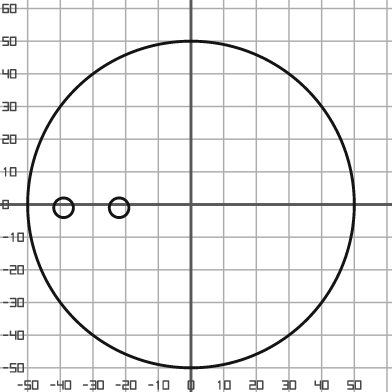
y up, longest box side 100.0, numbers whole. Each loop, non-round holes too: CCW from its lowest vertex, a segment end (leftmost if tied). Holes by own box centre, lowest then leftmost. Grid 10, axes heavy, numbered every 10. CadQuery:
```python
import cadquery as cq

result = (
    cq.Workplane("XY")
    .moveTo(0.0, 0.0)
    .circle(50.0)
    .moveTo(-39.0, -1.0)
    .circle(3.0)
    .moveTo(-22.0, -1.0)
    .circle(3.0)
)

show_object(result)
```